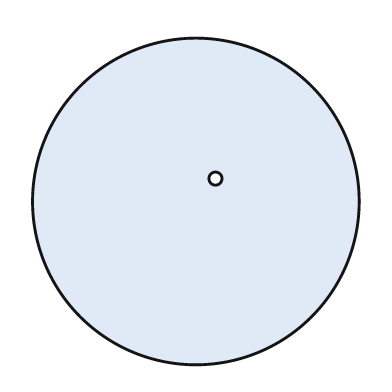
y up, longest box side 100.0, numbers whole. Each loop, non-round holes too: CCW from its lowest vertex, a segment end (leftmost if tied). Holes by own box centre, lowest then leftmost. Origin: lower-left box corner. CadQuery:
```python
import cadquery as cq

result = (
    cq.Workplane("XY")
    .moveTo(50.0, 50.0)
    .circle(50.0)
    .moveTo(56.0, 57.0)
    .circle(2.0)
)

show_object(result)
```